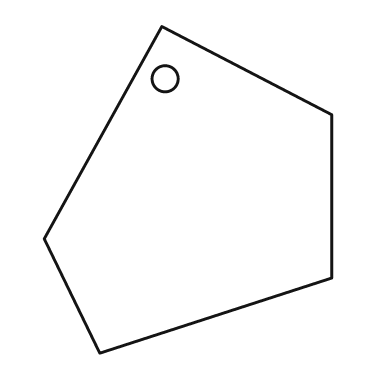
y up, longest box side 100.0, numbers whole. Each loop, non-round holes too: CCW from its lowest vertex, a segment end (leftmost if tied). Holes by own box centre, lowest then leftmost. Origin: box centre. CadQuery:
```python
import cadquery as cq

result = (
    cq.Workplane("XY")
    .moveTo(-27.0, -50.0)
    .lineTo(44.0, -27.0)
    .lineTo(44.0, 23.0)
    .lineTo(-8.0, 50.0)
    .lineTo(-44.0, -15.0)
    .close()
    .moveTo(-7.0, 34.0)
    .circle(4.0)
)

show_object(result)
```